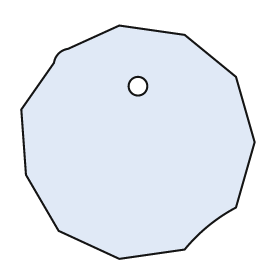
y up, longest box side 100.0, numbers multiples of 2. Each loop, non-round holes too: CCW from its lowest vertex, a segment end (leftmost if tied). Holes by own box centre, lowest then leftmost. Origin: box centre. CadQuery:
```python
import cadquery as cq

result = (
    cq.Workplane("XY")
    .moveTo(-8.0, -50.0)
    .lineTo(20.0, -46.0)
    .threePointArc((30.0, -36.0), (42.0, -28.0))
    .lineTo(50.0, 0.0)
    .lineTo(42.0, 28.0)
    .lineTo(20.0, 46.0)
    .lineTo(-8.0, 50.0)
    .lineTo(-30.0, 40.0)
    .threePointArc((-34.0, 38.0), (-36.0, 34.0))
    .lineTo(-50.0, 14.0)
    .lineTo(-48.0, -14.0)
    .lineTo(-34.0, -38.0)
    .close()
    .moveTo(0.0, 24.0)
    .circle(4.0)
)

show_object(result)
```